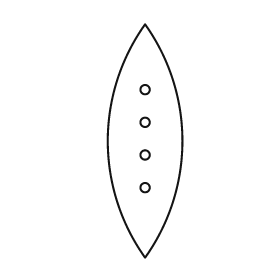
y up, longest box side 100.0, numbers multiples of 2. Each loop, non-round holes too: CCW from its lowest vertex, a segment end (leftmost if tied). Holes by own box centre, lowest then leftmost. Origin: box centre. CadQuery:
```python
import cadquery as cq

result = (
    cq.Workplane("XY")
    .moveTo(0.0, -50.0)
    .threePointArc((16.0, 0.0), (0.0, 50.0))
    .threePointArc((-16.0, 0.0), (0.0, -50.0))
    .close()
    .moveTo(0.0, -20.0)
    .circle(2.0)
    .moveTo(0.0, -6.0)
    .circle(2.0)
    .moveTo(0.0, 8.0)
    .circle(2.0)
    .moveTo(0.0, 22.0)
    .circle(2.0)
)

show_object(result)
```